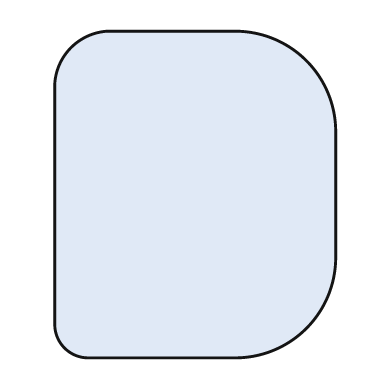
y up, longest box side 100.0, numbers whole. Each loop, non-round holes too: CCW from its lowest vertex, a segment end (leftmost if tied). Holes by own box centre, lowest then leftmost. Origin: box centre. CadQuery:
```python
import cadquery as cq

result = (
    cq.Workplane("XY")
    .moveTo(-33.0, -50.0)
    .lineTo(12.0, -50.0)
    .threePointArc((34.0, -41.0), (43.0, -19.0))
    .lineTo(43.0, 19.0)
    .threePointArc((34.0, 41.0), (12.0, 50.0))
    .lineTo(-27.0, 50.0)
    .threePointArc((-38.0, 45.0), (-43.0, 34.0))
    .lineTo(-43.0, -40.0)
    .threePointArc((-40.0, -47.0), (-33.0, -50.0))
    .close()
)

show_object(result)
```